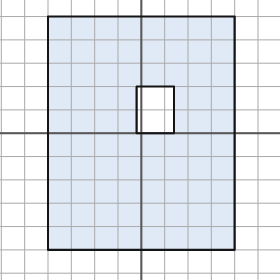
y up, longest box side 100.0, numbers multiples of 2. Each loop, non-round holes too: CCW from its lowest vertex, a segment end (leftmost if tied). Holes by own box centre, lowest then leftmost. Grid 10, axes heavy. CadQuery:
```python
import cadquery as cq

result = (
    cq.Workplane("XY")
    .moveTo(-40.0, -50.0)
    .lineTo(40.0, -50.0)
    .lineTo(40.0, 50.0)
    .lineTo(-40.0, 50.0)
    .close()
    .moveTo(-2.0, 0.0)
    .lineTo(14.0, 0.0)
    .lineTo(14.0, 20.0)
    .lineTo(-2.0, 20.0)
    .close()
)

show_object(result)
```